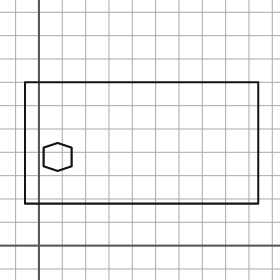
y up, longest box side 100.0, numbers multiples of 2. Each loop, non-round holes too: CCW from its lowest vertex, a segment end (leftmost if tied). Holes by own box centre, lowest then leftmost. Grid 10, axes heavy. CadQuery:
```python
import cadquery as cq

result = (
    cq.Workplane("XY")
    .moveTo(-6.0, 18.0)
    .lineTo(94.0, 18.0)
    .lineTo(94.0, 70.0)
    .lineTo(-6.0, 70.0)
    .close()
    .moveTo(8.0, 32.0)
    .lineTo(14.0, 34.0)
    .lineTo(14.0, 42.0)
    .lineTo(8.0, 44.0)
    .lineTo(2.0, 42.0)
    .lineTo(2.0, 34.0)
    .close()
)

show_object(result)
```